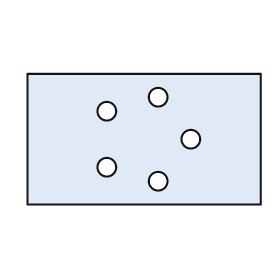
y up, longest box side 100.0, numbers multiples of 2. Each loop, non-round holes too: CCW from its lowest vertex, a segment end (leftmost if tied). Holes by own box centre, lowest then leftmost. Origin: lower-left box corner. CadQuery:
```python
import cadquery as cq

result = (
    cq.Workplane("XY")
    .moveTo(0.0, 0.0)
    .lineTo(100.0, 0.0)
    .lineTo(100.0, 56.0)
    .lineTo(0.0, 56.0)
    .close()
    .moveTo(56.0, 10.0)
    .circle(4.0)
    .moveTo(34.0, 16.0)
    .circle(4.0)
    .moveTo(70.0, 28.0)
    .circle(4.0)
    .moveTo(34.0, 40.0)
    .circle(4.0)
    .moveTo(56.0, 46.0)
    .circle(4.0)
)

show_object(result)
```